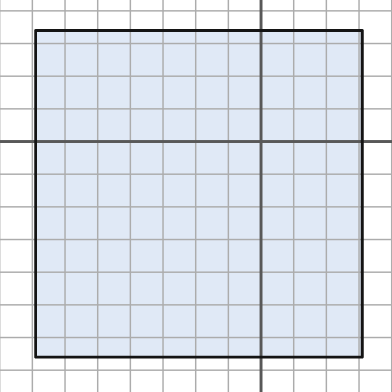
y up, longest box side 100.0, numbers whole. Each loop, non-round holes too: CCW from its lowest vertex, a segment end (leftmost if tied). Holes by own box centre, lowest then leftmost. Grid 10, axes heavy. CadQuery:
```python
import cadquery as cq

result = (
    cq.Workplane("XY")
    .moveTo(-69.0, -66.0)
    .lineTo(31.0, -66.0)
    .lineTo(31.0, 34.0)
    .lineTo(-69.0, 34.0)
    .close()
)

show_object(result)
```